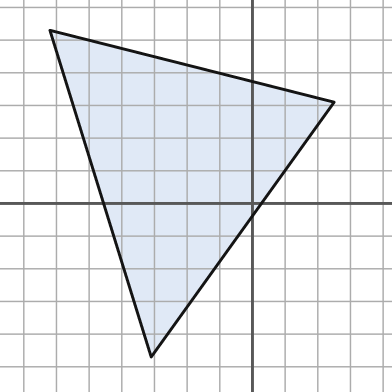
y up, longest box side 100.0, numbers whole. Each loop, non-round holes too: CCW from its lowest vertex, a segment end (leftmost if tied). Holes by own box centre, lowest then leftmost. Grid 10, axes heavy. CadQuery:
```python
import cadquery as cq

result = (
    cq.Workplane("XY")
    .moveTo(-31.0, -47.0)
    .lineTo(25.0, 31.0)
    .lineTo(-62.0, 53.0)
    .close()
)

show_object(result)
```